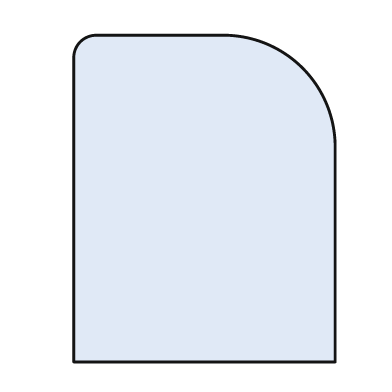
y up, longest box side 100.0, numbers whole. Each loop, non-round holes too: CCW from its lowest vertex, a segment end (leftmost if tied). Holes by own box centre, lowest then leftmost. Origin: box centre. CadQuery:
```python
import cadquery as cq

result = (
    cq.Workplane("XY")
    .moveTo(-40.0, -50.0)
    .lineTo(40.0, -50.0)
    .lineTo(40.0, 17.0)
    .threePointArc((30.0, 40.0), (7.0, 50.0))
    .lineTo(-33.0, 50.0)
    .threePointArc((-38.0, 48.0), (-40.0, 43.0))
    .close()
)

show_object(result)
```